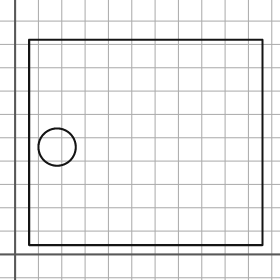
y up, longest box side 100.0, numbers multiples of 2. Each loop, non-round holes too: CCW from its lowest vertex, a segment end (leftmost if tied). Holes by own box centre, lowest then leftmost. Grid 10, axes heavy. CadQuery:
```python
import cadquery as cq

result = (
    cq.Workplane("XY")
    .moveTo(6.0, 4.0)
    .lineTo(106.0, 4.0)
    .lineTo(106.0, 92.0)
    .lineTo(6.0, 92.0)
    .close()
    .moveTo(18.0, 46.0)
    .circle(8.0)
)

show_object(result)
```